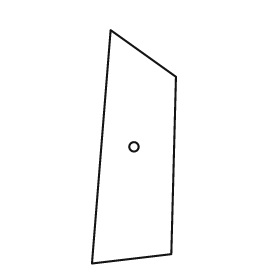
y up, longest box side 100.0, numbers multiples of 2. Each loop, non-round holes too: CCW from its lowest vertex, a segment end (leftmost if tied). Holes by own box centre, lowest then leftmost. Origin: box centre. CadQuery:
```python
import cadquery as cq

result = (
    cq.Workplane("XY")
    .moveTo(-18.0, -50.0)
    .lineTo(16.0, -46.0)
    .lineTo(18.0, 30.0)
    .lineTo(-10.0, 50.0)
    .close()
    .moveTo(0.0, 0.0)
    .circle(2.0)
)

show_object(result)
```